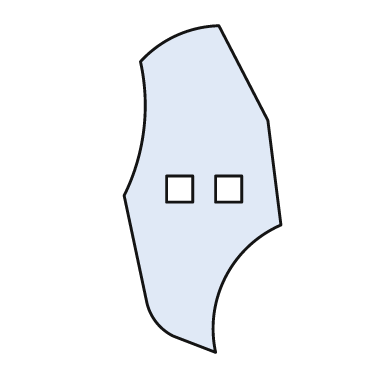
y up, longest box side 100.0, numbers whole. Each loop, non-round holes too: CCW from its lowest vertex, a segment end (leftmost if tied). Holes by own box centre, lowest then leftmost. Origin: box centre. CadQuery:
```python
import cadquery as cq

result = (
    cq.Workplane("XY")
    .moveTo(4.0, -50.0)
    .threePointArc((7.0, -27.0), (24.0, -11.0))
    .lineTo(20.0, 21.0)
    .lineTo(5.0, 50.0)
    .threePointArc((-8.0, 47.0), (-19.0, 39.0))
    .threePointArc((-18.0, 18.0), (-24.0, -2.0))
    .lineTo(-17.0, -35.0)
    .threePointArc((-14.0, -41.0), (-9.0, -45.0))
    .close()
    .moveTo(-11.0, -4.0)
    .lineTo(-3.0, -4.0)
    .lineTo(-3.0, 4.0)
    .lineTo(-11.0, 4.0)
    .close()
    .moveTo(4.0, -4.0)
    .lineTo(12.0, -4.0)
    .lineTo(12.0, 4.0)
    .lineTo(4.0, 4.0)
    .close()
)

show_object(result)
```